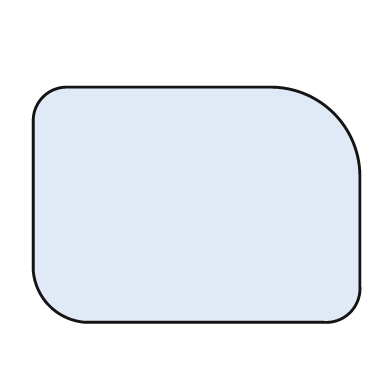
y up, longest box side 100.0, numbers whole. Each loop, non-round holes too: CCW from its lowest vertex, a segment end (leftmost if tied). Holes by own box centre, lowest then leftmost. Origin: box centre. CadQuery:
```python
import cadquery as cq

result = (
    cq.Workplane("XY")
    .moveTo(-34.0, -36.0)
    .lineTo(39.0, -36.0)
    .threePointArc((47.0, -33.0), (50.0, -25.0))
    .lineTo(50.0, 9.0)
    .threePointArc((42.0, 28.0), (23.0, 36.0))
    .lineTo(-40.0, 36.0)
    .threePointArc((-47.0, 33.0), (-50.0, 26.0))
    .lineTo(-50.0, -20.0)
    .threePointArc((-45.0, -31.0), (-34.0, -36.0))
    .close()
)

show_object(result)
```